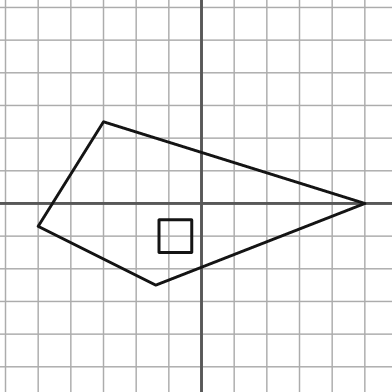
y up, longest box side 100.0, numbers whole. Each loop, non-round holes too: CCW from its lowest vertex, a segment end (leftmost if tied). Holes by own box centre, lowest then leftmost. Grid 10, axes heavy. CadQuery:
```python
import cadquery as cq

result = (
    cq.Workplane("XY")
    .moveTo(-14.0, -25.0)
    .lineTo(50.0, 0.0)
    .lineTo(-30.0, 25.0)
    .lineTo(-50.0, -7.0)
    .close()
    .moveTo(-13.0, -15.0)
    .lineTo(-3.0, -15.0)
    .lineTo(-3.0, -5.0)
    .lineTo(-13.0, -5.0)
    .close()
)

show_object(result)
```